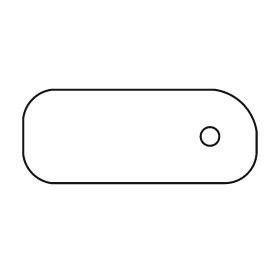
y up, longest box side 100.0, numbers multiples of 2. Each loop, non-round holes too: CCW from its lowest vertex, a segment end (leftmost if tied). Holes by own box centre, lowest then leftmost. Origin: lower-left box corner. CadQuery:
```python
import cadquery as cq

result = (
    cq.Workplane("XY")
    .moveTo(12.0, 0.0)
    .lineTo(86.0, 0.0)
    .threePointArc((96.0, 4.0), (100.0, 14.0))
    .lineTo(100.0, 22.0)
    .threePointArc((94.0, 34.0), (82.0, 40.0))
    .lineTo(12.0, 40.0)
    .threePointArc((4.0, 36.0), (0.0, 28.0))
    .lineTo(0.0, 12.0)
    .threePointArc((4.0, 4.0), (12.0, 0.0))
    .close()
    .moveTo(80.0, 20.0)
    .circle(4.0)
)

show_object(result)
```